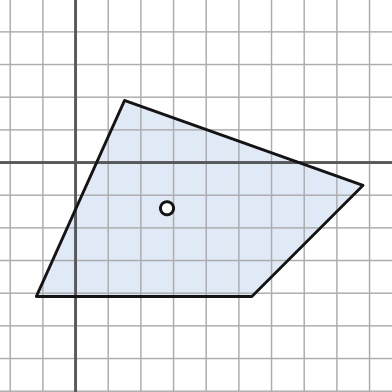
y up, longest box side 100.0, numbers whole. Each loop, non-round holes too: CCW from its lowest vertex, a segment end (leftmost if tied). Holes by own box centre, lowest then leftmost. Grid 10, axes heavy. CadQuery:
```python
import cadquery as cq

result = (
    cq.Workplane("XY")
    .moveTo(-12.0, -41.0)
    .lineTo(54.0, -41.0)
    .lineTo(88.0, -7.0)
    .lineTo(15.0, 19.0)
    .close()
    .moveTo(28.0, -14.0)
    .circle(2.0)
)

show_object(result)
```